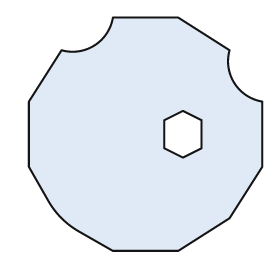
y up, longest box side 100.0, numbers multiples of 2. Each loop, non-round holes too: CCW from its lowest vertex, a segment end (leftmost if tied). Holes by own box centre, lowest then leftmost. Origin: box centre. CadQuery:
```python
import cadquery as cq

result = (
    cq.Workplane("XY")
    .moveTo(-14.0, -50.0)
    .lineTo(14.0, -50.0)
    .lineTo(36.0, -36.0)
    .lineTo(50.0, -14.0)
    .lineTo(50.0, 14.0)
    .threePointArc((38.0, 22.0), (36.0, 36.0))
    .lineTo(14.0, 50.0)
    .lineTo(-14.0, 50.0)
    .threePointArc((-22.0, 38.0), (-36.0, 36.0))
    .lineTo(-50.0, 14.0)
    .lineTo(-50.0, -14.0)
    .lineTo(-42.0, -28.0)
    .threePointArc((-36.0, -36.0), (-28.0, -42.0))
    .close()
    .moveTo(16.0, -10.0)
    .lineTo(24.0, -6.0)
    .lineTo(24.0, 6.0)
    .lineTo(16.0, 10.0)
    .lineTo(8.0, 6.0)
    .lineTo(8.0, -6.0)
    .close()
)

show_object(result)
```